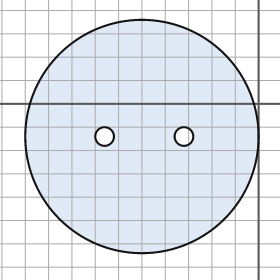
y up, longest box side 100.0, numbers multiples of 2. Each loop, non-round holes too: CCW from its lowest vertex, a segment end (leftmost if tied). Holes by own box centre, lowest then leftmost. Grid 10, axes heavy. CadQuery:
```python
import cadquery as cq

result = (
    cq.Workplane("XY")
    .moveTo(-50.0, -14.0)
    .circle(50.0)
    .moveTo(-66.0, -14.0)
    .circle(4.0)
    .moveTo(-32.0, -14.0)
    .circle(4.0)
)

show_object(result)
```